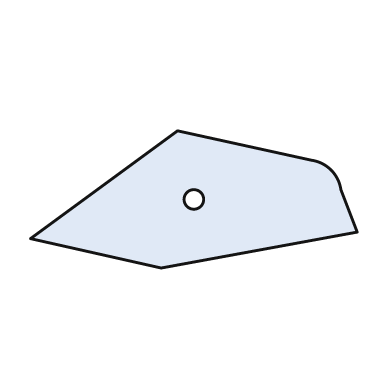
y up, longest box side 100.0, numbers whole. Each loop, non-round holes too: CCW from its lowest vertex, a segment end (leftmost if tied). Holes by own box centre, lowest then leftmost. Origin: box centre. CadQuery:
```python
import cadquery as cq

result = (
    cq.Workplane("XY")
    .moveTo(-10.0, -21.0)
    .lineTo(50.0, -10.0)
    .lineTo(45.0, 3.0)
    .threePointArc((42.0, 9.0), (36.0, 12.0))
    .lineTo(-5.0, 21.0)
    .lineTo(-50.0, -12.0)
    .close()
    .moveTo(0.0, 0.0)
    .circle(3.0)
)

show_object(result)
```